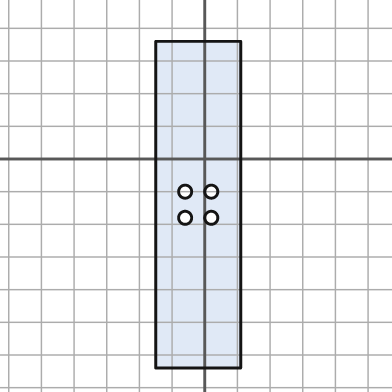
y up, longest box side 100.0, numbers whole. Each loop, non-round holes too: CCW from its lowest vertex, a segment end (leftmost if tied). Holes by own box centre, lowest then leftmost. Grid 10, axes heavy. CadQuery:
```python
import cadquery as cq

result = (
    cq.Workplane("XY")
    .moveTo(-15.0, -64.0)
    .lineTo(11.0, -64.0)
    .lineTo(11.0, 36.0)
    .lineTo(-15.0, 36.0)
    .close()
    .moveTo(-6.0, -18.0)
    .circle(2.0)
    .moveTo(2.0, -18.0)
    .circle(2.0)
    .moveTo(-6.0, -10.0)
    .circle(2.0)
    .moveTo(2.0, -10.0)
    .circle(2.0)
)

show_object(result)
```